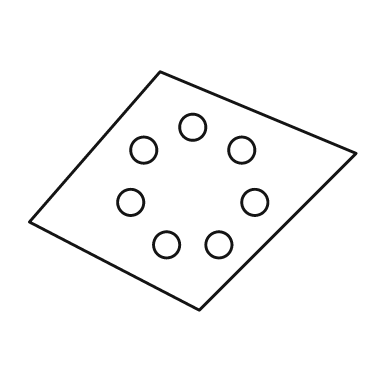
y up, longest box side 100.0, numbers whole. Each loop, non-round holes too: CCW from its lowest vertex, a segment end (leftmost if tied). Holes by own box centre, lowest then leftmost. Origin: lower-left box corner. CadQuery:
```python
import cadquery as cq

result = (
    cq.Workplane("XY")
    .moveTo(52.0, 0.0)
    .lineTo(100.0, 48.0)
    .lineTo(40.0, 73.0)
    .lineTo(0.0, 27.0)
    .close()
    .moveTo(42.0, 20.0)
    .circle(4.0)
    .moveTo(58.0, 20.0)
    .circle(4.0)
    .moveTo(31.0, 33.0)
    .circle(4.0)
    .moveTo(69.0, 33.0)
    .circle(4.0)
    .moveTo(35.0, 49.0)
    .circle(4.0)
    .moveTo(65.0, 49.0)
    .circle(4.0)
    .moveTo(50.0, 56.0)
    .circle(4.0)
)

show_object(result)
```